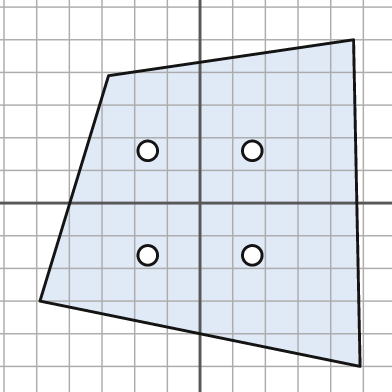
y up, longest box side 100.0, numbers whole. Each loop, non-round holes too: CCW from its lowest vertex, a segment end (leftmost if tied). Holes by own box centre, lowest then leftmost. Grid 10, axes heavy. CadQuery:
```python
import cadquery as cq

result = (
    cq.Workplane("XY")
    .moveTo(49.0, -50.0)
    .lineTo(47.0, 50.0)
    .lineTo(-28.0, 39.0)
    .lineTo(-49.0, -30.0)
    .close()
    .moveTo(-16.0, -16.0)
    .circle(3.0)
    .moveTo(16.0, -16.0)
    .circle(3.0)
    .moveTo(-16.0, 16.0)
    .circle(3.0)
    .moveTo(16.0, 16.0)
    .circle(3.0)
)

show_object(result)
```